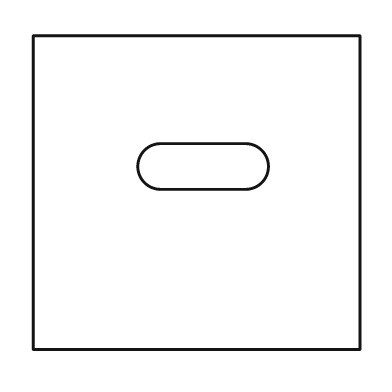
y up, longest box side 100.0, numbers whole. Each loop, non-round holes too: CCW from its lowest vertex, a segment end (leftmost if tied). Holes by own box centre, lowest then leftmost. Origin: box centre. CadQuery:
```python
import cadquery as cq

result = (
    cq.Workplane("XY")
    .moveTo(-50.0, -48.0)
    .lineTo(50.0, -48.0)
    .lineTo(50.0, 48.0)
    .lineTo(-50.0, 48.0)
    .close()
    .moveTo(-11.0, 1.0)
    .lineTo(15.0, 1.0)
    .threePointArc((22.0, 8.0), (15.0, 15.0))
    .lineTo(-11.0, 15.0)
    .threePointArc((-18.0, 8.0), (-11.0, 1.0))
    .close()
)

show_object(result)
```